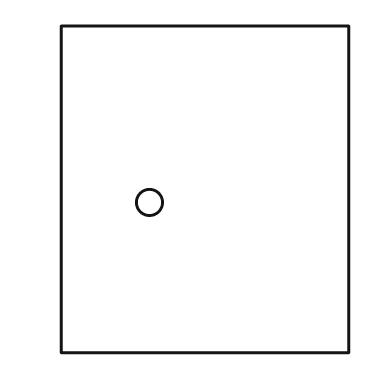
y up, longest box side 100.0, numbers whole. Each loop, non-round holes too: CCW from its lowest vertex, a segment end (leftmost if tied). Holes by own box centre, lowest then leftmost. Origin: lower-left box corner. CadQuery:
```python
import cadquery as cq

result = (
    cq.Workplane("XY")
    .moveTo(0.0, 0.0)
    .lineTo(88.0, 0.0)
    .lineTo(88.0, 100.0)
    .lineTo(0.0, 100.0)
    .close()
    .moveTo(27.0, 46.0)
    .circle(4.0)
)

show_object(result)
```